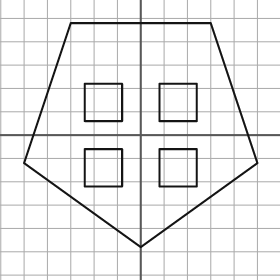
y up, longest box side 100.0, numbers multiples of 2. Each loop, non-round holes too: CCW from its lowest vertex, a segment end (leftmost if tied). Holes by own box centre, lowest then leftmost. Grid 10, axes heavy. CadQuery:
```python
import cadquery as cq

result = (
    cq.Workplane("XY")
    .moveTo(0.0, -48.0)
    .lineTo(50.0, -12.0)
    .lineTo(30.0, 48.0)
    .lineTo(-30.0, 48.0)
    .lineTo(-50.0, -12.0)
    .close()
    .moveTo(-24.0, -22.0)
    .lineTo(-8.0, -22.0)
    .lineTo(-8.0, -6.0)
    .lineTo(-24.0, -6.0)
    .close()
    .moveTo(8.0, -22.0)
    .lineTo(24.0, -22.0)
    .lineTo(24.0, -6.0)
    .lineTo(8.0, -6.0)
    .close()
    .moveTo(-24.0, 6.0)
    .lineTo(-8.0, 6.0)
    .lineTo(-8.0, 22.0)
    .lineTo(-24.0, 22.0)
    .close()
    .moveTo(8.0, 6.0)
    .lineTo(24.0, 6.0)
    .lineTo(24.0, 22.0)
    .lineTo(8.0, 22.0)
    .close()
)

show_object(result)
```